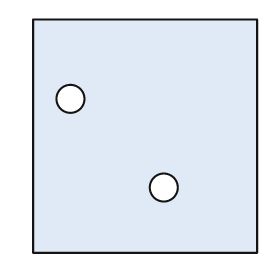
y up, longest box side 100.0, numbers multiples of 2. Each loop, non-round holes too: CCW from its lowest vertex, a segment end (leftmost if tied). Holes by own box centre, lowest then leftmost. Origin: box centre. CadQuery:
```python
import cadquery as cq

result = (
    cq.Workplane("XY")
    .moveTo(-48.0, -50.0)
    .lineTo(48.0, -50.0)
    .lineTo(48.0, 50.0)
    .lineTo(-48.0, 50.0)
    .close()
    .moveTo(8.0, -22.0)
    .circle(6.0)
    .moveTo(-32.0, 16.0)
    .circle(6.0)
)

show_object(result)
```